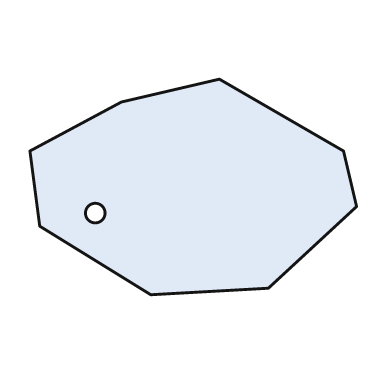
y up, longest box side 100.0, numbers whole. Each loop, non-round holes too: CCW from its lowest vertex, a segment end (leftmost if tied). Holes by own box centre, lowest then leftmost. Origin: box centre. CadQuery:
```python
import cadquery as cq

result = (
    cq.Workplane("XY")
    .moveTo(-13.0, -33.0)
    .lineTo(23.0, -31.0)
    .lineTo(50.0, -6.0)
    .lineTo(46.0, 11.0)
    .lineTo(8.0, 33.0)
    .lineTo(-22.0, 26.0)
    .lineTo(-50.0, 11.0)
    .lineTo(-47.0, -12.0)
    .close()
    .moveTo(-30.0, -8.0)
    .circle(3.0)
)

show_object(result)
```